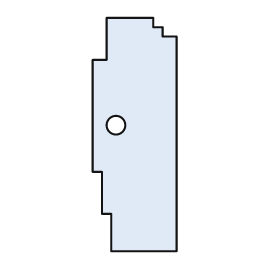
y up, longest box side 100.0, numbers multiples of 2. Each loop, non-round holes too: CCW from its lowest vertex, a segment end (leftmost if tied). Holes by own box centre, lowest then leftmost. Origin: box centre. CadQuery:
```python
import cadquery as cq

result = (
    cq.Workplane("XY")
    .moveTo(-10.0, -50.0)
    .lineTo(18.0, -50.0)
    .lineTo(18.0, 42.0)
    .lineTo(12.0, 42.0)
    .lineTo(12.0, 46.0)
    .lineTo(8.0, 46.0)
    .lineTo(8.0, 50.0)
    .lineTo(-12.0, 50.0)
    .lineTo(-12.0, 32.0)
    .lineTo(-18.0, 32.0)
    .lineTo(-18.0, -16.0)
    .lineTo(-14.0, -16.0)
    .lineTo(-14.0, -34.0)
    .lineTo(-10.0, -34.0)
    .close()
    .moveTo(-8.0, 4.0)
    .circle(4.0)
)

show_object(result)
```